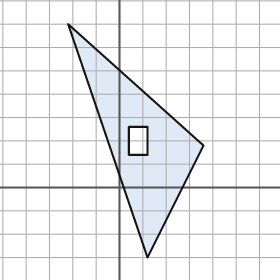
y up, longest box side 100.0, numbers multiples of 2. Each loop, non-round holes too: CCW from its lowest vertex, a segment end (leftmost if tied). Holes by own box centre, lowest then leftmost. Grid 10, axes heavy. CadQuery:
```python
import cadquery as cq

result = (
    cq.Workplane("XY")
    .moveTo(12.0, -30.0)
    .lineTo(36.0, 18.0)
    .lineTo(-22.0, 70.0)
    .close()
    .moveTo(4.0, 14.0)
    .lineTo(12.0, 14.0)
    .lineTo(12.0, 26.0)
    .lineTo(4.0, 26.0)
    .close()
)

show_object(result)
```